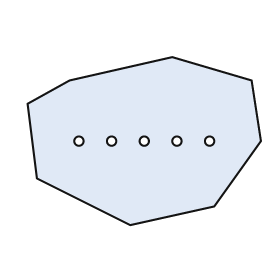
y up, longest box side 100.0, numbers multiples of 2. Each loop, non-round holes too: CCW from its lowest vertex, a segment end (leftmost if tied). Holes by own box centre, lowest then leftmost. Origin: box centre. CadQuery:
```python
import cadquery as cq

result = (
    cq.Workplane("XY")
    .moveTo(-6.0, -36.0)
    .lineTo(30.0, -28.0)
    .lineTo(50.0, 0.0)
    .lineTo(46.0, 26.0)
    .lineTo(12.0, 36.0)
    .lineTo(-32.0, 26.0)
    .lineTo(-50.0, 16.0)
    .lineTo(-46.0, -16.0)
    .close()
    .moveTo(-28.0, 0.0)
    .circle(2.0)
    .moveTo(-14.0, 0.0)
    .circle(2.0)
    .moveTo(0.0, 0.0)
    .circle(2.0)
    .moveTo(14.0, 0.0)
    .circle(2.0)
    .moveTo(28.0, 0.0)
    .circle(2.0)
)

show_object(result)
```